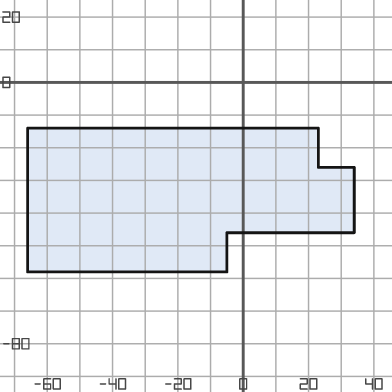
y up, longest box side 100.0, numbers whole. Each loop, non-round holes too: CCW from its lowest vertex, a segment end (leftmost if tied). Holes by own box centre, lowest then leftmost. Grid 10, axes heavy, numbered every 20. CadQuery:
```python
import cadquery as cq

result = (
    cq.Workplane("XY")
    .moveTo(-66.0, -58.0)
    .lineTo(-5.0, -58.0)
    .lineTo(-5.0, -46.0)
    .lineTo(34.0, -46.0)
    .lineTo(34.0, -26.0)
    .lineTo(23.0, -26.0)
    .lineTo(23.0, -14.0)
    .lineTo(-66.0, -14.0)
    .close()
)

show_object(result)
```